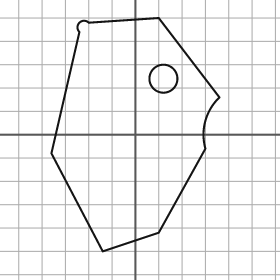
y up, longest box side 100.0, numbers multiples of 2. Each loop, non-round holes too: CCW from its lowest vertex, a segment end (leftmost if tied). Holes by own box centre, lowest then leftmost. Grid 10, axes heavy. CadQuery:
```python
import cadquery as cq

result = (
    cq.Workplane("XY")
    .moveTo(-14.0, -50.0)
    .lineTo(10.0, -42.0)
    .lineTo(30.0, -6.0)
    .threePointArc((30.0, 6.0), (36.0, 16.0))
    .lineTo(10.0, 50.0)
    .lineTo(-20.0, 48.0)
    .threePointArc((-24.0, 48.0), (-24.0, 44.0))
    .lineTo(-36.0, -8.0)
    .close()
    .moveTo(12.0, 24.0)
    .circle(6.0)
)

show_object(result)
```